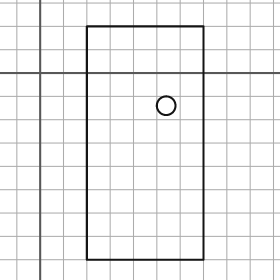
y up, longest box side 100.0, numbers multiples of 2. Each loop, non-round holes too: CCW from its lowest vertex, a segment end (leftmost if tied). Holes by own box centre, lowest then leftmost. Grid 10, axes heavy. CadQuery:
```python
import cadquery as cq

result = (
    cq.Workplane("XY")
    .moveTo(20.0, -80.0)
    .lineTo(70.0, -80.0)
    .lineTo(70.0, 20.0)
    .lineTo(20.0, 20.0)
    .close()
    .moveTo(54.0, -14.0)
    .circle(4.0)
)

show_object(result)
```